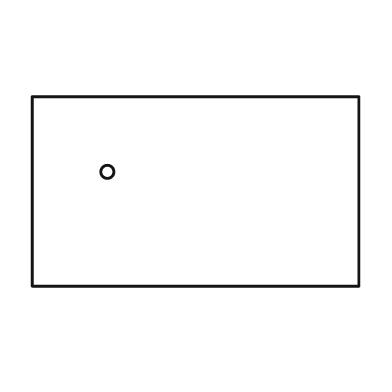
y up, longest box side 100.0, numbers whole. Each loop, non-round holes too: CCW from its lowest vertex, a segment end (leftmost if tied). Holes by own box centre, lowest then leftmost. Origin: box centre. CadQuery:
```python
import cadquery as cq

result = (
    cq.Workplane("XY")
    .moveTo(-50.0, -29.0)
    .lineTo(50.0, -29.0)
    .lineTo(50.0, 29.0)
    .lineTo(-50.0, 29.0)
    .close()
    .moveTo(-27.0, 6.0)
    .circle(2.0)
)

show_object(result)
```